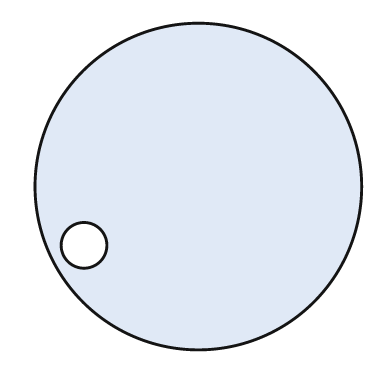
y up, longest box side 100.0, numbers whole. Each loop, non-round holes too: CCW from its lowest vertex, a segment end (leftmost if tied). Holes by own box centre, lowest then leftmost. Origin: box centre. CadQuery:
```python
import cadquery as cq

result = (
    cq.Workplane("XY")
    .moveTo(0.0, 0.0)
    .circle(50.0)
    .moveTo(-35.0, -18.0)
    .circle(7.0)
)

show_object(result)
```